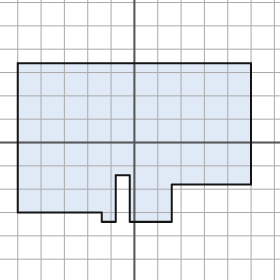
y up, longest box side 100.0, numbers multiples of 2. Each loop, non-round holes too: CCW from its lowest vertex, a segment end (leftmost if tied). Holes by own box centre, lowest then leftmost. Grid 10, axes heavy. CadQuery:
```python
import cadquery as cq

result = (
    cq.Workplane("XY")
    .moveTo(-14.0, -34.0)
    .lineTo(-8.0, -34.0)
    .lineTo(-8.0, -14.0)
    .lineTo(-2.0, -14.0)
    .lineTo(-2.0, -34.0)
    .lineTo(16.0, -34.0)
    .lineTo(16.0, -18.0)
    .lineTo(50.0, -18.0)
    .lineTo(50.0, 34.0)
    .lineTo(-50.0, 34.0)
    .lineTo(-50.0, -30.0)
    .lineTo(-14.0, -30.0)
    .close()
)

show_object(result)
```